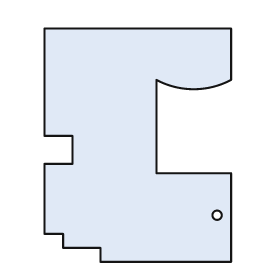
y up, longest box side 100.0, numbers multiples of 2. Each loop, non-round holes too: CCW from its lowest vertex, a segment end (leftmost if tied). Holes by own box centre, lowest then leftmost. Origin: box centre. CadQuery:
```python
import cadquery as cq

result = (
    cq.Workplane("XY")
    .moveTo(-16.0, -50.0)
    .lineTo(40.0, -50.0)
    .lineTo(40.0, -12.0)
    .lineTo(8.0, -12.0)
    .lineTo(8.0, 28.0)
    .threePointArc((24.0, 24.0), (40.0, 28.0))
    .lineTo(40.0, 50.0)
    .lineTo(-40.0, 50.0)
    .lineTo(-40.0, 4.0)
    .lineTo(-28.0, 4.0)
    .lineTo(-28.0, -8.0)
    .lineTo(-40.0, -8.0)
    .lineTo(-40.0, -38.0)
    .lineTo(-32.0, -38.0)
    .lineTo(-32.0, -44.0)
    .lineTo(-16.0, -44.0)
    .close()
    .moveTo(34.0, -30.0)
    .circle(2.0)
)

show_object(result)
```